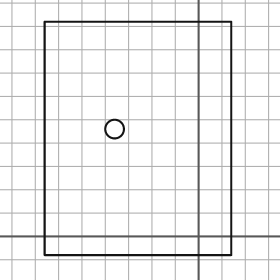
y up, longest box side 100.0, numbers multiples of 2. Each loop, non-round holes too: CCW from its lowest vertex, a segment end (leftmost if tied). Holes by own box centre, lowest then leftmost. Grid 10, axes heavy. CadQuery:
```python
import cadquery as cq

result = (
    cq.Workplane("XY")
    .moveTo(-66.0, -8.0)
    .lineTo(14.0, -8.0)
    .lineTo(14.0, 92.0)
    .lineTo(-66.0, 92.0)
    .close()
    .moveTo(-36.0, 46.0)
    .circle(4.0)
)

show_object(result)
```